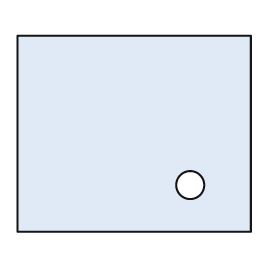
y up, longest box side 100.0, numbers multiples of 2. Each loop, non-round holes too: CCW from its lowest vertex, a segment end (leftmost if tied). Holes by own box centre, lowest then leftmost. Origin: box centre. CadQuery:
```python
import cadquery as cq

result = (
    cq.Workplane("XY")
    .moveTo(-50.0, -42.0)
    .lineTo(50.0, -42.0)
    .lineTo(50.0, 42.0)
    .lineTo(-50.0, 42.0)
    .close()
    .moveTo(24.0, -22.0)
    .circle(6.0)
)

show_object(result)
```